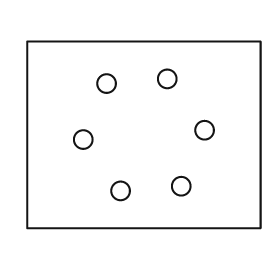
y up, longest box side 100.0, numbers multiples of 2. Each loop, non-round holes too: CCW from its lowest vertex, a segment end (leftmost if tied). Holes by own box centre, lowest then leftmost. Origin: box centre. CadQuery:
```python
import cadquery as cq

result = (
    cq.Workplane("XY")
    .moveTo(-50.0, -40.0)
    .lineTo(50.0, -40.0)
    .lineTo(50.0, 40.0)
    .lineTo(-50.0, 40.0)
    .close()
    .moveTo(-10.0, -24.0)
    .circle(4.0)
    .moveTo(16.0, -22.0)
    .circle(4.0)
    .moveTo(-26.0, -2.0)
    .circle(4.0)
    .moveTo(26.0, 2.0)
    .circle(4.0)
    .moveTo(-16.0, 22.0)
    .circle(4.0)
    .moveTo(10.0, 24.0)
    .circle(4.0)
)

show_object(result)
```